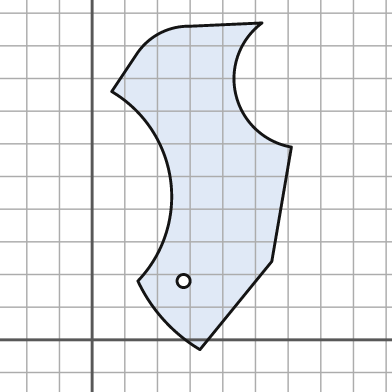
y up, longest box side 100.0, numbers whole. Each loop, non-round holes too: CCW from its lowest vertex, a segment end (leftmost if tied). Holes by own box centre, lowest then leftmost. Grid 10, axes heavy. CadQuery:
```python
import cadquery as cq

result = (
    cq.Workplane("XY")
    .moveTo(33.0, -3.0)
    .lineTo(55.0, 24.0)
    .lineTo(61.0, 59.0)
    .threePointArc((44.0, 75.0), (52.0, 97.0))
    .lineTo(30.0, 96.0)
    .threePointArc((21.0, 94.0), (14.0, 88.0))
    .lineTo(6.0, 76.0)
    .threePointArc((24.0, 49.0), (14.0, 18.0))
    .threePointArc((22.0, 6.0), (33.0, -3.0))
    .close()
    .moveTo(28.0, 18.0)
    .circle(2.0)
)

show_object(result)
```